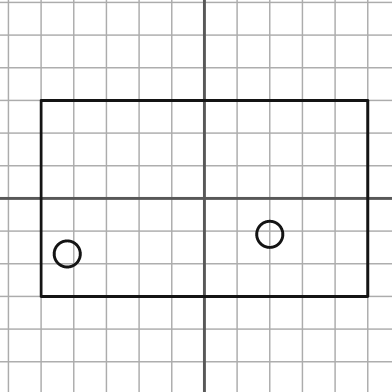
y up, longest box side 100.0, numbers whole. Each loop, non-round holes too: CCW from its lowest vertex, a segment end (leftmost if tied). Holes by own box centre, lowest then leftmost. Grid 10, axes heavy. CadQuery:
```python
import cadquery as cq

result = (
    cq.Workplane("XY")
    .moveTo(-50.0, -30.0)
    .lineTo(50.0, -30.0)
    .lineTo(50.0, 30.0)
    .lineTo(-50.0, 30.0)
    .close()
    .moveTo(-42.0, -17.0)
    .circle(4.0)
    .moveTo(20.0, -11.0)
    .circle(4.0)
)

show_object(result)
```